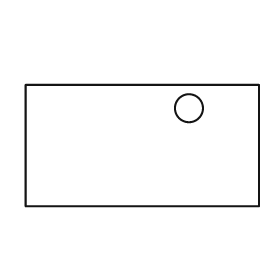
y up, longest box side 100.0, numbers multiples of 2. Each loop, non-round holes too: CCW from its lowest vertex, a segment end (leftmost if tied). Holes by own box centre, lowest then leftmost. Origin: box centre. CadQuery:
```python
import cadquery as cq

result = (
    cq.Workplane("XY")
    .moveTo(-50.0, -26.0)
    .lineTo(50.0, -26.0)
    .lineTo(50.0, 26.0)
    .lineTo(-50.0, 26.0)
    .close()
    .moveTo(20.0, 16.0)
    .circle(6.0)
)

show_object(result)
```